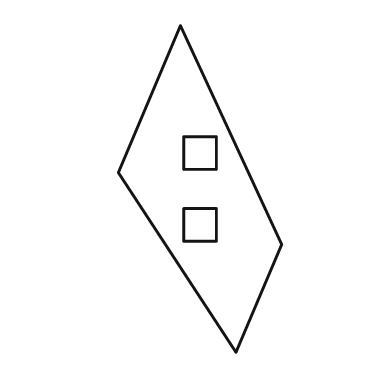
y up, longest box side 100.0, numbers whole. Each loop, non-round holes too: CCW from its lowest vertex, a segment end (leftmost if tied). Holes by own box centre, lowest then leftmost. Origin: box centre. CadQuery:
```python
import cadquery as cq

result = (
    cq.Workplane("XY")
    .moveTo(11.0, -50.0)
    .lineTo(25.0, -17.0)
    .lineTo(-6.0, 50.0)
    .lineTo(-25.0, 5.0)
    .close()
    .moveTo(-5.0, -16.0)
    .lineTo(5.0, -16.0)
    .lineTo(5.0, -6.0)
    .lineTo(-5.0, -6.0)
    .close()
    .moveTo(-5.0, 6.0)
    .lineTo(5.0, 6.0)
    .lineTo(5.0, 16.0)
    .lineTo(-5.0, 16.0)
    .close()
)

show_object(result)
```